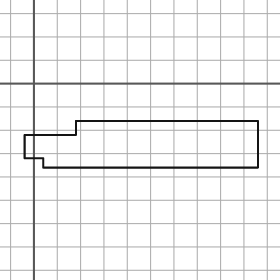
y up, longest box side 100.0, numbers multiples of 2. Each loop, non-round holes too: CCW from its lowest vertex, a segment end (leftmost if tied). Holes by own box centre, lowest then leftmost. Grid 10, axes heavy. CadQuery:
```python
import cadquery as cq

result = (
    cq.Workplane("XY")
    .moveTo(4.0, -36.0)
    .lineTo(96.0, -36.0)
    .lineTo(96.0, -16.0)
    .lineTo(18.0, -16.0)
    .lineTo(18.0, -22.0)
    .lineTo(-4.0, -22.0)
    .lineTo(-4.0, -32.0)
    .lineTo(4.0, -32.0)
    .close()
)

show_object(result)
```